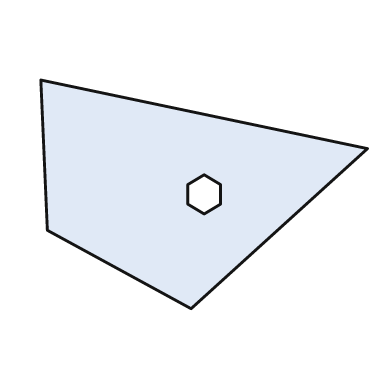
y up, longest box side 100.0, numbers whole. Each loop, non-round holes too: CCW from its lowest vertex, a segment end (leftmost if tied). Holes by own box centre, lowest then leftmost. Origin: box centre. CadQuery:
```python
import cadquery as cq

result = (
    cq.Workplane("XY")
    .moveTo(-4.0, -35.0)
    .lineTo(50.0, 14.0)
    .lineTo(-50.0, 35.0)
    .lineTo(-48.0, -11.0)
    .close()
    .moveTo(0.0, -6.0)
    .lineTo(5.0, -3.0)
    .lineTo(5.0, 3.0)
    .lineTo(0.0, 6.0)
    .lineTo(-5.0, 3.0)
    .lineTo(-5.0, -3.0)
    .close()
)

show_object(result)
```